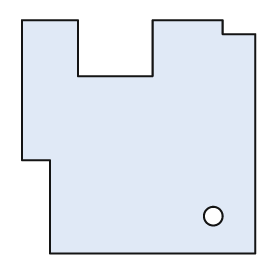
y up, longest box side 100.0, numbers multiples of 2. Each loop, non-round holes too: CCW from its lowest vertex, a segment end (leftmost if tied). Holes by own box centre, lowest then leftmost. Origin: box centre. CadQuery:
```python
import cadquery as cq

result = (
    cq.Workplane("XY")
    .moveTo(-38.0, -50.0)
    .lineTo(50.0, -50.0)
    .lineTo(50.0, 44.0)
    .lineTo(36.0, 44.0)
    .lineTo(36.0, 50.0)
    .lineTo(6.0, 50.0)
    .lineTo(6.0, 26.0)
    .lineTo(-26.0, 26.0)
    .lineTo(-26.0, 50.0)
    .lineTo(-50.0, 50.0)
    .lineTo(-50.0, -10.0)
    .lineTo(-38.0, -10.0)
    .close()
    .moveTo(32.0, -34.0)
    .circle(4.0)
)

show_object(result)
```